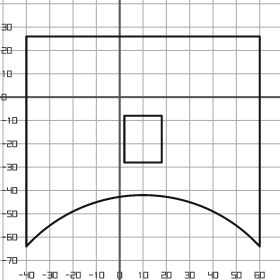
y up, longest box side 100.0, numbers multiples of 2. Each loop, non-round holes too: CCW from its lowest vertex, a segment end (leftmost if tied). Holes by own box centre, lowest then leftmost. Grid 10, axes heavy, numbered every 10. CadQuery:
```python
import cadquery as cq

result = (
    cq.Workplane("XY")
    .moveTo(-40.0, -64.0)
    .threePointArc((10.0, -42.0), (60.0, -64.0))
    .lineTo(60.0, 26.0)
    .lineTo(-40.0, 26.0)
    .close()
    .moveTo(2.0, -28.0)
    .lineTo(18.0, -28.0)
    .lineTo(18.0, -8.0)
    .lineTo(2.0, -8.0)
    .close()
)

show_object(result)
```